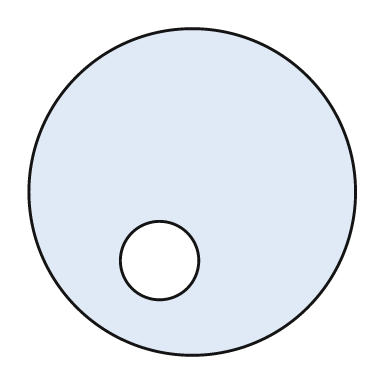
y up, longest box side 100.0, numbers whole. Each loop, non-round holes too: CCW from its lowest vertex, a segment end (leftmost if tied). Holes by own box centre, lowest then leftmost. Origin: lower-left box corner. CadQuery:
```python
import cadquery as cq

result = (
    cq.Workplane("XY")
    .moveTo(50.0, 50.0)
    .circle(50.0)
    .moveTo(40.0, 29.0)
    .circle(12.0)
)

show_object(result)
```